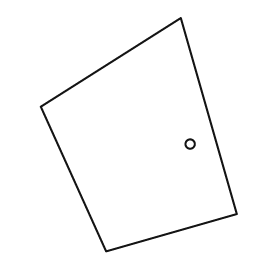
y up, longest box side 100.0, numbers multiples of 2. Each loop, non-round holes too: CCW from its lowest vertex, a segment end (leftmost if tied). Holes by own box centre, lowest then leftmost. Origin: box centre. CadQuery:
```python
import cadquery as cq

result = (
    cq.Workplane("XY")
    .moveTo(-14.0, -50.0)
    .lineTo(42.0, -34.0)
    .lineTo(18.0, 50.0)
    .lineTo(-42.0, 12.0)
    .close()
    .moveTo(22.0, -4.0)
    .circle(2.0)
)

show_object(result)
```